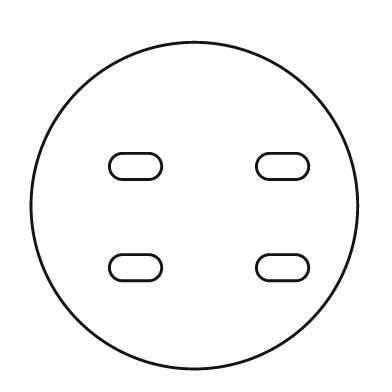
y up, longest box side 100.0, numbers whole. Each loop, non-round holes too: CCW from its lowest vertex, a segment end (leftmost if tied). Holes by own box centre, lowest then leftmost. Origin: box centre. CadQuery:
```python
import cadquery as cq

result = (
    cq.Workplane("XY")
    .moveTo(0.0, 0.0)
    .circle(50.0)
    .moveTo(-22.0, -23.0)
    .lineTo(-14.0, -23.0)
    .threePointArc((-10.0, -19.0), (-14.0, -15.0))
    .lineTo(-22.0, -15.0)
    .threePointArc((-26.0, -19.0), (-22.0, -23.0))
    .close()
    .moveTo(23.0, -23.0)
    .lineTo(31.0, -23.0)
    .threePointArc((35.0, -19.0), (31.0, -15.0))
    .lineTo(23.0, -15.0)
    .threePointArc((19.0, -19.0), (23.0, -23.0))
    .close()
    .moveTo(-22.0, 8.0)
    .lineTo(-14.0, 8.0)
    .threePointArc((-10.0, 12.0), (-14.0, 16.0))
    .lineTo(-22.0, 16.0)
    .threePointArc((-26.0, 12.0), (-22.0, 8.0))
    .close()
    .moveTo(23.0, 8.0)
    .lineTo(31.0, 8.0)
    .threePointArc((35.0, 12.0), (31.0, 16.0))
    .lineTo(23.0, 16.0)
    .threePointArc((19.0, 12.0), (23.0, 8.0))
    .close()
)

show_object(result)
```